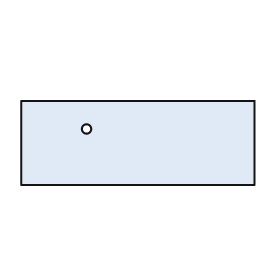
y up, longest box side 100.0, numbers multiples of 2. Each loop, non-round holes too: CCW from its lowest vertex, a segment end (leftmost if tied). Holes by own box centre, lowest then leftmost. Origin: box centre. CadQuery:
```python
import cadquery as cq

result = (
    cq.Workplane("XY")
    .moveTo(-50.0, -18.0)
    .lineTo(50.0, -18.0)
    .lineTo(50.0, 18.0)
    .lineTo(-50.0, 18.0)
    .close()
    .moveTo(-22.0, 6.0)
    .circle(2.0)
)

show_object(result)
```